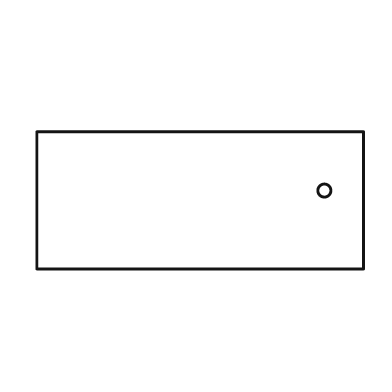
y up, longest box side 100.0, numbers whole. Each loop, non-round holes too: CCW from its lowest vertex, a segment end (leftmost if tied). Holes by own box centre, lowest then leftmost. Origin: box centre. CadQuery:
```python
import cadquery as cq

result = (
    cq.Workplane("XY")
    .moveTo(-50.0, -21.0)
    .lineTo(50.0, -21.0)
    .lineTo(50.0, 21.0)
    .lineTo(-50.0, 21.0)
    .close()
    .moveTo(38.0, 3.0)
    .circle(2.0)
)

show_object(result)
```